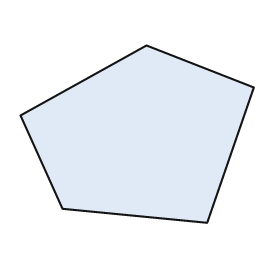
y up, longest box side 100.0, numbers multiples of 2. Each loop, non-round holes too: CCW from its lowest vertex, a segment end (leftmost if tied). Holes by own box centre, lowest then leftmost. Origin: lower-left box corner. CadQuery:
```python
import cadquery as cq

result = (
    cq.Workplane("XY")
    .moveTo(80.0, 0.0)
    .lineTo(100.0, 58.0)
    .lineTo(54.0, 76.0)
    .lineTo(0.0, 46.0)
    .lineTo(18.0, 6.0)
    .close()
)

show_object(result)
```